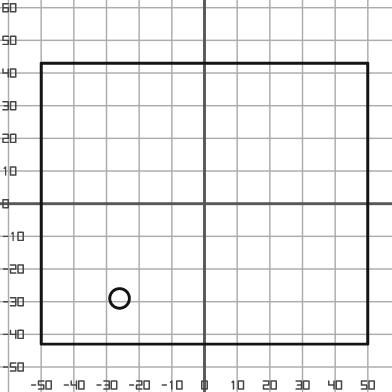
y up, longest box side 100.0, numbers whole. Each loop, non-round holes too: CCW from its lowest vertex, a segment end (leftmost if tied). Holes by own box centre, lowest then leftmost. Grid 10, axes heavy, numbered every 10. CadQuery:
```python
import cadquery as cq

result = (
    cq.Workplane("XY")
    .moveTo(-50.0, -43.0)
    .lineTo(50.0, -43.0)
    .lineTo(50.0, 43.0)
    .lineTo(-50.0, 43.0)
    .close()
    .moveTo(-26.0, -29.0)
    .circle(3.0)
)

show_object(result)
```